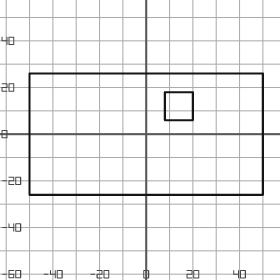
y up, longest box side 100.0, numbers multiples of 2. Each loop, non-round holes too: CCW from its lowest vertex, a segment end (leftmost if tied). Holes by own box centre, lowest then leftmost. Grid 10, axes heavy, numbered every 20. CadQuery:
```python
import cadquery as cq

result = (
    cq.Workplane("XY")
    .moveTo(-50.0, -26.0)
    .lineTo(50.0, -26.0)
    .lineTo(50.0, 26.0)
    .lineTo(-50.0, 26.0)
    .close()
    .moveTo(8.0, 6.0)
    .lineTo(20.0, 6.0)
    .lineTo(20.0, 18.0)
    .lineTo(8.0, 18.0)
    .close()
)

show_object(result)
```